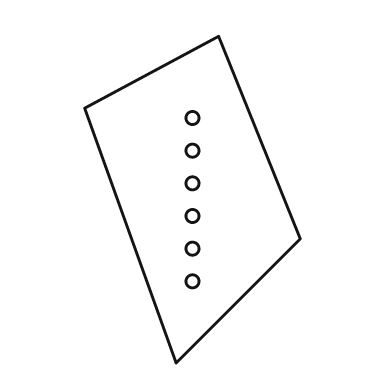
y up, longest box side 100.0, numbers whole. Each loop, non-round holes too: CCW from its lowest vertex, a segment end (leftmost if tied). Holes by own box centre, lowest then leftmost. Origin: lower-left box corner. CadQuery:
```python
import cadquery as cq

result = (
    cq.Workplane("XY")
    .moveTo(28.0, 0.0)
    .lineTo(66.0, 38.0)
    .lineTo(41.0, 100.0)
    .lineTo(0.0, 78.0)
    .close()
    .moveTo(33.0, 25.0)
    .circle(2.0)
    .moveTo(33.0, 35.0)
    .circle(2.0)
    .moveTo(33.0, 45.0)
    .circle(2.0)
    .moveTo(33.0, 55.0)
    .circle(2.0)
    .moveTo(33.0, 65.0)
    .circle(2.0)
    .moveTo(33.0, 75.0)
    .circle(2.0)
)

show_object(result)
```